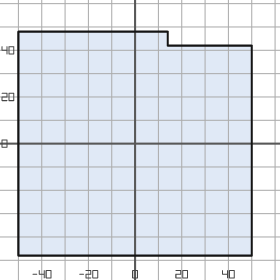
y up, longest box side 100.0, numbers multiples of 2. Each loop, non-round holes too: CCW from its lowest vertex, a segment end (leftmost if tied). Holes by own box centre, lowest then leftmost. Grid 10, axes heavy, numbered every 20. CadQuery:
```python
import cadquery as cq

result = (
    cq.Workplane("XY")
    .moveTo(-50.0, -48.0)
    .lineTo(50.0, -48.0)
    .lineTo(50.0, 42.0)
    .lineTo(14.0, 42.0)
    .lineTo(14.0, 48.0)
    .lineTo(-50.0, 48.0)
    .close()
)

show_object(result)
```